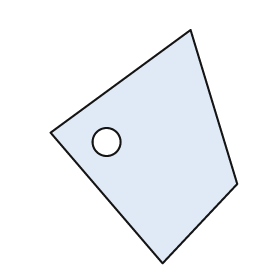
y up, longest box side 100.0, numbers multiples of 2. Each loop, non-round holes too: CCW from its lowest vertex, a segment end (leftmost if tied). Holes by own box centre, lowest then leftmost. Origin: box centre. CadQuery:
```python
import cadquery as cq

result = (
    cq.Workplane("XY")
    .moveTo(8.0, -50.0)
    .lineTo(40.0, -16.0)
    .lineTo(20.0, 50.0)
    .lineTo(-40.0, 6.0)
    .close()
    .moveTo(-16.0, 2.0)
    .circle(6.0)
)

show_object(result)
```